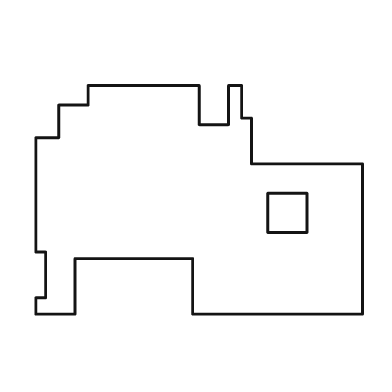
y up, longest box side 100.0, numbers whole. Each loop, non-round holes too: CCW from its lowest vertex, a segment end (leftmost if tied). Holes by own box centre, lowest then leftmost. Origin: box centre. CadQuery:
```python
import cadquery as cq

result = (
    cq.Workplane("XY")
    .moveTo(-50.0, -35.0)
    .lineTo(-38.0, -35.0)
    .lineTo(-38.0, -18.0)
    .lineTo(-2.0, -18.0)
    .lineTo(-2.0, -35.0)
    .lineTo(50.0, -35.0)
    .lineTo(50.0, 11.0)
    .lineTo(16.0, 11.0)
    .lineTo(16.0, 25.0)
    .lineTo(13.0, 25.0)
    .lineTo(13.0, 35.0)
    .lineTo(9.0, 35.0)
    .lineTo(9.0, 23.0)
    .lineTo(0.0, 23.0)
    .lineTo(0.0, 35.0)
    .lineTo(-34.0, 35.0)
    .lineTo(-34.0, 29.0)
    .lineTo(-43.0, 29.0)
    .lineTo(-43.0, 19.0)
    .lineTo(-50.0, 19.0)
    .lineTo(-50.0, -16.0)
    .lineTo(-47.0, -16.0)
    .lineTo(-47.0, -30.0)
    .lineTo(-50.0, -30.0)
    .close()
    .moveTo(21.0, -10.0)
    .lineTo(33.0, -10.0)
    .lineTo(33.0, 2.0)
    .lineTo(21.0, 2.0)
    .close()
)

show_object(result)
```